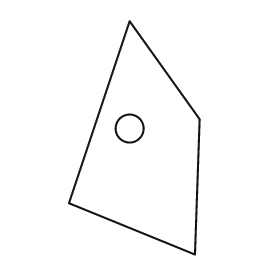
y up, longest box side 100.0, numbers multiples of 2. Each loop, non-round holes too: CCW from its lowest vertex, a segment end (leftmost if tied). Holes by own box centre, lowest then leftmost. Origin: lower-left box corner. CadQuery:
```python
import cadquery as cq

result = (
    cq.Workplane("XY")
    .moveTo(54.0, 0.0)
    .lineTo(56.0, 58.0)
    .lineTo(26.0, 100.0)
    .lineTo(0.0, 22.0)
    .close()
    .moveTo(26.0, 54.0)
    .circle(6.0)
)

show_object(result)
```